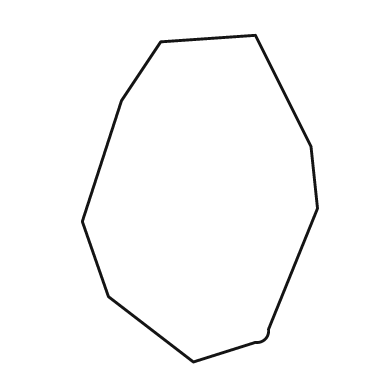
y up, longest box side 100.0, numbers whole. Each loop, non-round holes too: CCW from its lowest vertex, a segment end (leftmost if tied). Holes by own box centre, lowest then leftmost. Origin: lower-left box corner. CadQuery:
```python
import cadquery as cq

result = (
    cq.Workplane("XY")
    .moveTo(34.0, 0.0)
    .lineTo(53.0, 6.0)
    .threePointArc((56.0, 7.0), (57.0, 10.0))
    .lineTo(72.0, 47.0)
    .lineTo(70.0, 66.0)
    .lineTo(53.0, 100.0)
    .lineTo(24.0, 98.0)
    .lineTo(12.0, 80.0)
    .lineTo(0.0, 43.0)
    .lineTo(8.0, 20.0)
    .close()
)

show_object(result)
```